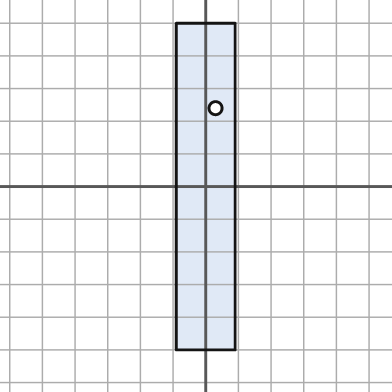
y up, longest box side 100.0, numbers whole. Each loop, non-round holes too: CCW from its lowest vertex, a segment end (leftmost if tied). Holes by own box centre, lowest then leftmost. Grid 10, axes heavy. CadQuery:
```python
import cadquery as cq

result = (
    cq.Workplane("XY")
    .moveTo(-9.0, -50.0)
    .lineTo(9.0, -50.0)
    .lineTo(9.0, 50.0)
    .lineTo(-9.0, 50.0)
    .close()
    .moveTo(3.0, 24.0)
    .circle(2.0)
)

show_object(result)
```